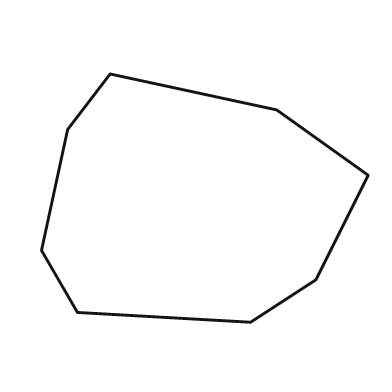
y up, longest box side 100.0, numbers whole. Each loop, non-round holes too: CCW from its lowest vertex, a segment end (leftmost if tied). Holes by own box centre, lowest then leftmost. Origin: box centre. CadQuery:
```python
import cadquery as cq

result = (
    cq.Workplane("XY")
    .moveTo(14.0, -38.0)
    .lineTo(34.0, -25.0)
    .lineTo(50.0, 7.0)
    .lineTo(22.0, 27.0)
    .lineTo(-29.0, 38.0)
    .lineTo(-42.0, 21.0)
    .lineTo(-50.0, -16.0)
    .lineTo(-39.0, -35.0)
    .close()
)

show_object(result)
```